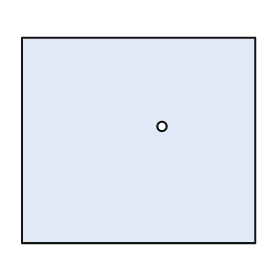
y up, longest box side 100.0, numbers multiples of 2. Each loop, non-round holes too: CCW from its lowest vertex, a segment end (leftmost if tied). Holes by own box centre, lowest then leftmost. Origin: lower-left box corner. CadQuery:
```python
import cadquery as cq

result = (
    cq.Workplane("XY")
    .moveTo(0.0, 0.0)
    .lineTo(100.0, 0.0)
    .lineTo(100.0, 88.0)
    .lineTo(0.0, 88.0)
    .close()
    .moveTo(60.0, 50.0)
    .circle(2.0)
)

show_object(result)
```